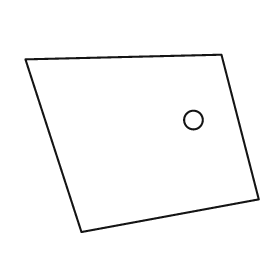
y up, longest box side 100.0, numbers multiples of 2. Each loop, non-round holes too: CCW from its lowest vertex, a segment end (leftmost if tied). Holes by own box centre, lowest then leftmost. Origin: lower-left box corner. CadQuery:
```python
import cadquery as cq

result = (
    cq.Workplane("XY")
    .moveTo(24.0, 0.0)
    .lineTo(100.0, 14.0)
    .lineTo(84.0, 76.0)
    .lineTo(0.0, 74.0)
    .close()
    .moveTo(72.0, 48.0)
    .circle(4.0)
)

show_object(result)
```